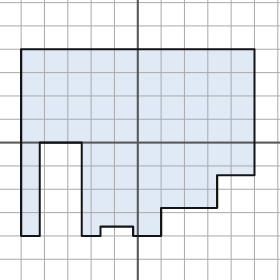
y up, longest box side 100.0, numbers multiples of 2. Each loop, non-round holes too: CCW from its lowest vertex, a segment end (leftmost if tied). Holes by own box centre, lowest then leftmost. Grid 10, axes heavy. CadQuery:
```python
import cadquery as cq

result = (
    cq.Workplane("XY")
    .moveTo(-50.0, -40.0)
    .lineTo(-42.0, -40.0)
    .lineTo(-42.0, 0.0)
    .lineTo(-24.0, 0.0)
    .lineTo(-24.0, -40.0)
    .lineTo(-16.0, -40.0)
    .lineTo(-16.0, -36.0)
    .lineTo(-2.0, -36.0)
    .lineTo(-2.0, -40.0)
    .lineTo(10.0, -40.0)
    .lineTo(10.0, -28.0)
    .lineTo(34.0, -28.0)
    .lineTo(34.0, -14.0)
    .lineTo(50.0, -14.0)
    .lineTo(50.0, 40.0)
    .lineTo(-50.0, 40.0)
    .close()
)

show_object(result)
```